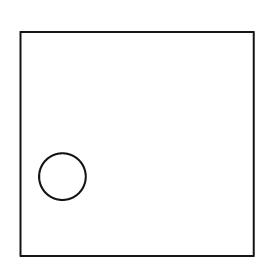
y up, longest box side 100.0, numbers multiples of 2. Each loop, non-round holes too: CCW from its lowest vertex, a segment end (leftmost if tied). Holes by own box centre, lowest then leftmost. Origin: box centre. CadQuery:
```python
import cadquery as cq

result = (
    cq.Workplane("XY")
    .moveTo(-50.0, -48.0)
    .lineTo(50.0, -48.0)
    .lineTo(50.0, 48.0)
    .lineTo(-50.0, 48.0)
    .close()
    .moveTo(-32.0, -14.0)
    .circle(10.0)
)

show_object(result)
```